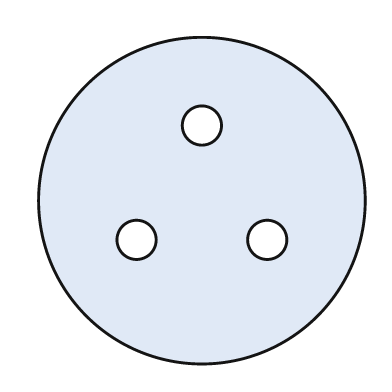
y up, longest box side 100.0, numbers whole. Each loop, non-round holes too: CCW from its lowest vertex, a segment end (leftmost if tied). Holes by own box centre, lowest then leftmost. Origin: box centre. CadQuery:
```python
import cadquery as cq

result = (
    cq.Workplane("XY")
    .moveTo(0.0, 0.0)
    .circle(50.0)
    .moveTo(-20.0, -12.0)
    .circle(6.0)
    .moveTo(20.0, -12.0)
    .circle(6.0)
    .moveTo(0.0, 23.0)
    .circle(6.0)
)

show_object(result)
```